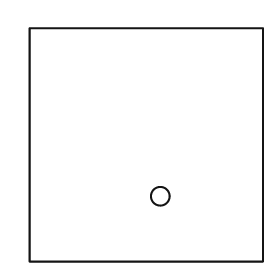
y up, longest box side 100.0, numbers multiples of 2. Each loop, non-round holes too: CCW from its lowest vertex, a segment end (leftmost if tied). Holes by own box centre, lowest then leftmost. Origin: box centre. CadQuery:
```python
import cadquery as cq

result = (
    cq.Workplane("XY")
    .moveTo(-50.0, -50.0)
    .lineTo(50.0, -50.0)
    .lineTo(50.0, 50.0)
    .lineTo(-50.0, 50.0)
    .close()
    .moveTo(6.0, -22.0)
    .circle(4.0)
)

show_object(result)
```